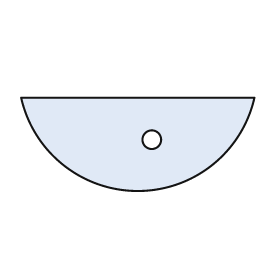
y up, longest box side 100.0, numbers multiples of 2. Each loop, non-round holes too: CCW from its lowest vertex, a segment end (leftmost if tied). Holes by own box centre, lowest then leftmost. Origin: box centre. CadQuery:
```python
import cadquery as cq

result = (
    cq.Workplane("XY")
    .moveTo(-50.0, 20.0)
    .threePointArc((0.0, -20.0), (50.0, 20.0))
    .close()
    .moveTo(6.0, 2.0)
    .circle(4.0)
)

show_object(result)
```